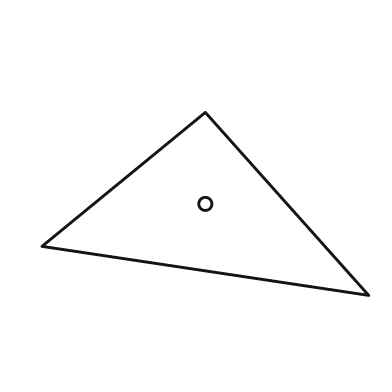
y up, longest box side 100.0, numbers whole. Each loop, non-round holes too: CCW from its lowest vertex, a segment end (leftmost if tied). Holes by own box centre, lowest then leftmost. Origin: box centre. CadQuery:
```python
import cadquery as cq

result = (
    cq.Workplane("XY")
    .moveTo(50.0, -28.0)
    .lineTo(0.0, 28.0)
    .lineTo(-50.0, -13.0)
    .close()
    .moveTo(0.0, 0.0)
    .circle(2.0)
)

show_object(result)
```